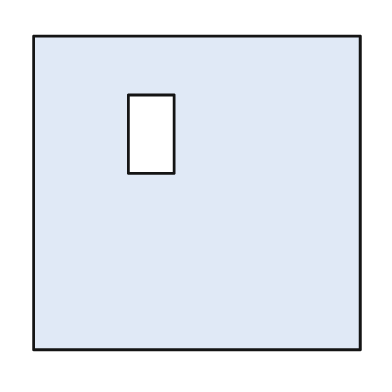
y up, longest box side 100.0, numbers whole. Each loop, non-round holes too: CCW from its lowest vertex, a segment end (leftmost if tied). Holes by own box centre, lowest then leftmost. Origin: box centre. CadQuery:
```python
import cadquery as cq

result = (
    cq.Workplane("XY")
    .moveTo(-50.0, -48.0)
    .lineTo(50.0, -48.0)
    .lineTo(50.0, 48.0)
    .lineTo(-50.0, 48.0)
    .close()
    .moveTo(-21.0, 6.0)
    .lineTo(-7.0, 6.0)
    .lineTo(-7.0, 30.0)
    .lineTo(-21.0, 30.0)
    .close()
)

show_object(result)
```